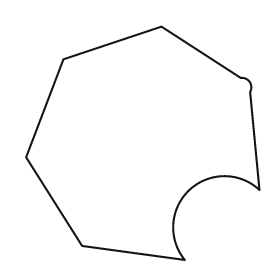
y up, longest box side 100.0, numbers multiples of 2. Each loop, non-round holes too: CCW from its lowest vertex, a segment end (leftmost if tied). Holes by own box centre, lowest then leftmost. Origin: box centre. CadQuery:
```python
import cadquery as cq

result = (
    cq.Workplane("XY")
    .moveTo(18.0, -50.0)
    .threePointArc((20.0, -20.0), (50.0, -20.0))
    .lineTo(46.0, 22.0)
    .threePointArc((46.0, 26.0), (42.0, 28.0))
    .lineTo(8.0, 50.0)
    .lineTo(-34.0, 36.0)
    .lineTo(-50.0, -6.0)
    .lineTo(-26.0, -44.0)
    .close()
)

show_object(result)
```